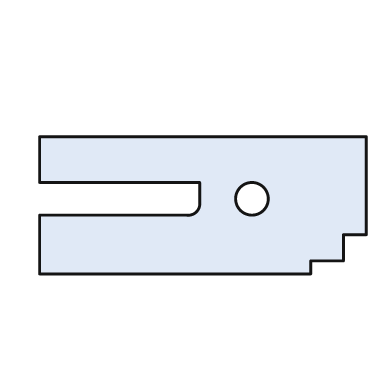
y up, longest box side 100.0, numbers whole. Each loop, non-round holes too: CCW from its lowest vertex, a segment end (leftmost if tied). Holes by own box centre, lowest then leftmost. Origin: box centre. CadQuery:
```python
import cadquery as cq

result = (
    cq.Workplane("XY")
    .moveTo(-50.0, -21.0)
    .lineTo(33.0, -21.0)
    .lineTo(33.0, -17.0)
    .lineTo(43.0, -17.0)
    .lineTo(43.0, -9.0)
    .lineTo(50.0, -9.0)
    .lineTo(50.0, 21.0)
    .lineTo(-50.0, 21.0)
    .lineTo(-50.0, 7.0)
    .lineTo(-1.0, 7.0)
    .lineTo(-1.0, 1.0)
    .threePointArc((-2.0, -2.0), (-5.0, -3.0))
    .lineTo(-50.0, -3.0)
    .close()
    .moveTo(15.0, 2.0)
    .circle(5.0)
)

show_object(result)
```